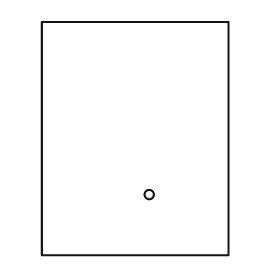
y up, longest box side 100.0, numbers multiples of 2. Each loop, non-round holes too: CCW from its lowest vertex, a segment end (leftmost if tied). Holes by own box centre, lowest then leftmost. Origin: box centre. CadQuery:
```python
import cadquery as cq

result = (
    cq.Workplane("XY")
    .moveTo(-40.0, -50.0)
    .lineTo(40.0, -50.0)
    .lineTo(40.0, 50.0)
    .lineTo(-40.0, 50.0)
    .close()
    .moveTo(6.0, -24.0)
    .circle(2.0)
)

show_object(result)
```